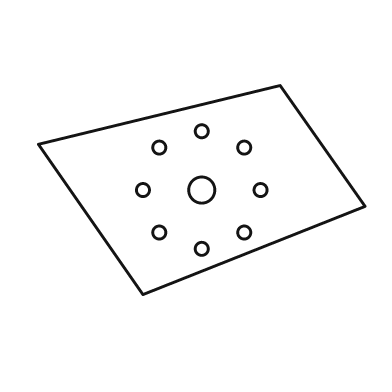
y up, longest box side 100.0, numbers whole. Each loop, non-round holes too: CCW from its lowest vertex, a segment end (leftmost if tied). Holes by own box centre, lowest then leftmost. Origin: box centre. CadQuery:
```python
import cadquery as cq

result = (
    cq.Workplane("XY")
    .moveTo(-18.0, -32.0)
    .lineTo(50.0, -5.0)
    .lineTo(24.0, 32.0)
    .lineTo(-50.0, 14.0)
    .close()
    .moveTo(0.0, -18.0)
    .circle(2.0)
    .moveTo(-13.0, -13.0)
    .circle(2.0)
    .moveTo(13.0, -13.0)
    .circle(2.0)
    .moveTo(-18.0, 0.0)
    .circle(2.0)
    .moveTo(0.0, 0.0)
    .circle(4.0)
    .moveTo(18.0, 0.0)
    .circle(2.0)
    .moveTo(-13.0, 13.0)
    .circle(2.0)
    .moveTo(13.0, 13.0)
    .circle(2.0)
    .moveTo(0.0, 18.0)
    .circle(2.0)
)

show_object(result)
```